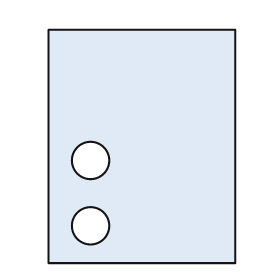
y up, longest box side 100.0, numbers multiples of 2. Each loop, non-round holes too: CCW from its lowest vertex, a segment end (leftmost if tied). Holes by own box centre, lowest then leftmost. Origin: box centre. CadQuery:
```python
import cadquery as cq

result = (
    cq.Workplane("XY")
    .moveTo(-40.0, -50.0)
    .lineTo(40.0, -50.0)
    .lineTo(40.0, 50.0)
    .lineTo(-40.0, 50.0)
    .close()
    .moveTo(-22.0, -34.0)
    .circle(8.0)
    .moveTo(-22.0, -6.0)
    .circle(8.0)
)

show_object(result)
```